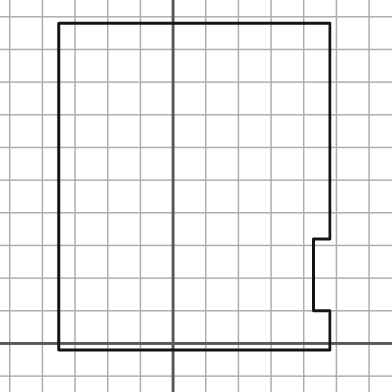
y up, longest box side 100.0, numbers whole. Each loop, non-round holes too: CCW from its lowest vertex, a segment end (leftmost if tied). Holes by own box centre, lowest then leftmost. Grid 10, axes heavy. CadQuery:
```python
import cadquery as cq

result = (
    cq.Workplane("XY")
    .moveTo(-35.0, -2.0)
    .lineTo(48.0, -2.0)
    .lineTo(48.0, 10.0)
    .lineTo(43.0, 10.0)
    .lineTo(43.0, 32.0)
    .lineTo(48.0, 32.0)
    .lineTo(48.0, 98.0)
    .lineTo(-35.0, 98.0)
    .close()
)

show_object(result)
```